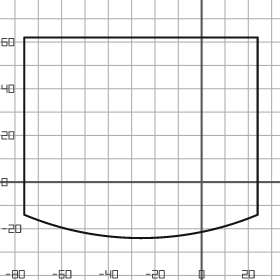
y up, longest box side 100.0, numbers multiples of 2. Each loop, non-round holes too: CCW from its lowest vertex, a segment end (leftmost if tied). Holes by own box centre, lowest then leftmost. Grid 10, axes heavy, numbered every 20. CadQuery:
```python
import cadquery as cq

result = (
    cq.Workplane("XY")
    .moveTo(-76.0, -14.0)
    .threePointArc((-26.0, -24.0), (24.0, -14.0))
    .lineTo(24.0, 62.0)
    .lineTo(-76.0, 62.0)
    .close()
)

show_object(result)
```